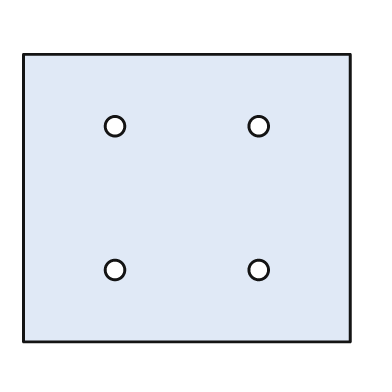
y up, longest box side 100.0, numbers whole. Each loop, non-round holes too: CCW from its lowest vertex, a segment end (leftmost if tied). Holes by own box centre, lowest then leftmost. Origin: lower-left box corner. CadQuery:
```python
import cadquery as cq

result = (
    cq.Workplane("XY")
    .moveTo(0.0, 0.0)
    .lineTo(100.0, 0.0)
    .lineTo(100.0, 88.0)
    .lineTo(0.0, 88.0)
    .close()
    .moveTo(28.0, 22.0)
    .circle(3.0)
    .moveTo(72.0, 22.0)
    .circle(3.0)
    .moveTo(28.0, 66.0)
    .circle(3.0)
    .moveTo(72.0, 66.0)
    .circle(3.0)
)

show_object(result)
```